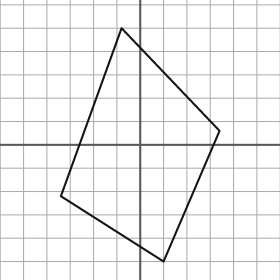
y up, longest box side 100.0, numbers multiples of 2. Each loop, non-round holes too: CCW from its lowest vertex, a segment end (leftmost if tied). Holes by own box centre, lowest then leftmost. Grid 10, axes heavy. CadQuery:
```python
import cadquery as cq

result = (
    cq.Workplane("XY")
    .moveTo(10.0, -50.0)
    .lineTo(34.0, 6.0)
    .lineTo(-8.0, 50.0)
    .lineTo(-34.0, -22.0)
    .close()
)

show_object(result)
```